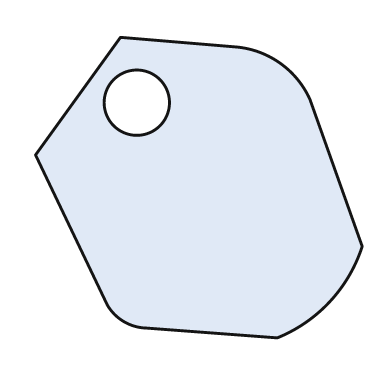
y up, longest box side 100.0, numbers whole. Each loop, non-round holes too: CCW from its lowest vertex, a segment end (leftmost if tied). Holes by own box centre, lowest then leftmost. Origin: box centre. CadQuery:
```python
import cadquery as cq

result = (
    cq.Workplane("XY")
    .moveTo(24.0, -46.0)
    .threePointArc((40.0, -35.0), (50.0, -18.0))
    .lineTo(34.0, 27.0)
    .threePointArc((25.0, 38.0), (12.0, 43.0))
    .lineTo(-24.0, 46.0)
    .lineTo(-50.0, 10.0)
    .lineTo(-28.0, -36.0)
    .threePointArc((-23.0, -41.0), (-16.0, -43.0))
    .close()
    .moveTo(-19.0, 26.0)
    .circle(10.0)
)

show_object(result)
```